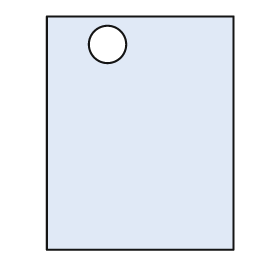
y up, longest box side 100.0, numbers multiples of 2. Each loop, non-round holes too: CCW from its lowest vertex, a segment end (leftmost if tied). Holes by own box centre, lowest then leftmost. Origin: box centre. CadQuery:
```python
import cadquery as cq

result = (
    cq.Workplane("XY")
    .moveTo(-40.0, -50.0)
    .lineTo(40.0, -50.0)
    .lineTo(40.0, 50.0)
    .lineTo(-40.0, 50.0)
    .close()
    .moveTo(-14.0, 38.0)
    .circle(8.0)
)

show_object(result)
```